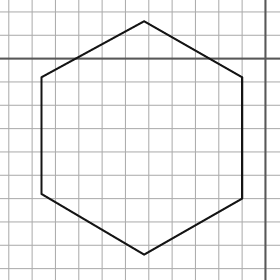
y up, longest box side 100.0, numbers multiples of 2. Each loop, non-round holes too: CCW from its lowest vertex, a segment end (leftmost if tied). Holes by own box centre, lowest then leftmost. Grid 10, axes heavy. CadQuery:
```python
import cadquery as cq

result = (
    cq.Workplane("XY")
    .moveTo(-52.0, -84.0)
    .lineTo(-10.0, -60.0)
    .lineTo(-10.0, -8.0)
    .lineTo(-52.0, 16.0)
    .lineTo(-96.0, -8.0)
    .lineTo(-96.0, -58.0)
    .close()
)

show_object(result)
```